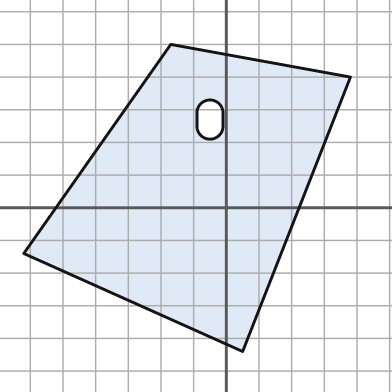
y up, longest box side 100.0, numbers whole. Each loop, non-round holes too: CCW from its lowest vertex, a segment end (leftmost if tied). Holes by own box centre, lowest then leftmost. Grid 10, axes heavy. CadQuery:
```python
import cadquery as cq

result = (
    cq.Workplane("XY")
    .moveTo(5.0, -44.0)
    .lineTo(38.0, 40.0)
    .lineTo(-17.0, 50.0)
    .lineTo(-62.0, -14.0)
    .close()
    .moveTo(-9.0, 25.0)
    .threePointArc((-5.0, 21.0), (-1.0, 25.0))
    .lineTo(-1.0, 29.0)
    .threePointArc((-5.0, 33.0), (-9.0, 29.0))
    .close()
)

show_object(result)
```